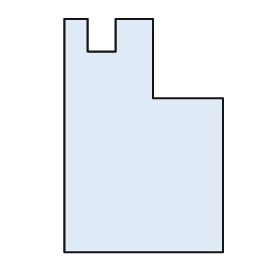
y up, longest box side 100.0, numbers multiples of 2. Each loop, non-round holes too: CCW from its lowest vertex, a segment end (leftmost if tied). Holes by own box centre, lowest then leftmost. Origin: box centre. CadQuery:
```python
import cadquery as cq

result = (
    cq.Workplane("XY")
    .moveTo(-34.0, -50.0)
    .lineTo(34.0, -50.0)
    .lineTo(34.0, 16.0)
    .lineTo(4.0, 16.0)
    .lineTo(4.0, 50.0)
    .lineTo(-12.0, 50.0)
    .lineTo(-12.0, 36.0)
    .lineTo(-24.0, 36.0)
    .lineTo(-24.0, 50.0)
    .lineTo(-34.0, 50.0)
    .close()
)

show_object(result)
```